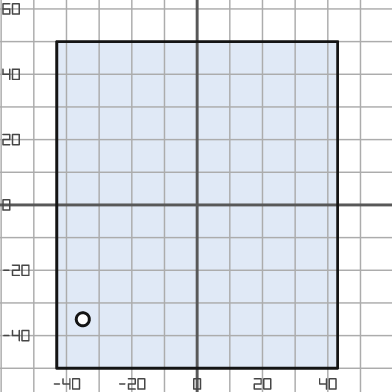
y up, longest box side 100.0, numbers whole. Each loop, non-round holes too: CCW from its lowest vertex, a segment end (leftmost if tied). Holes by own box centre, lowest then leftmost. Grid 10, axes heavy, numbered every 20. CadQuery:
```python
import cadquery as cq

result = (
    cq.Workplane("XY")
    .moveTo(-43.0, -50.0)
    .lineTo(43.0, -50.0)
    .lineTo(43.0, 50.0)
    .lineTo(-43.0, 50.0)
    .close()
    .moveTo(-35.0, -35.0)
    .circle(2.0)
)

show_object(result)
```